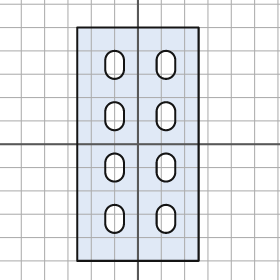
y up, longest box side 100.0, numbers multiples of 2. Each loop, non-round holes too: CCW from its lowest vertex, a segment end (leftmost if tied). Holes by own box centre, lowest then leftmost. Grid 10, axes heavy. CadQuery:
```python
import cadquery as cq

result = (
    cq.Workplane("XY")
    .moveTo(-26.0, -50.0)
    .lineTo(26.0, -50.0)
    .lineTo(26.0, 50.0)
    .lineTo(-26.0, 50.0)
    .close()
    .moveTo(-14.0, -34.0)
    .threePointArc((-10.0, -38.0), (-6.0, -34.0))
    .lineTo(-6.0, -30.0)
    .threePointArc((-10.0, -26.0), (-14.0, -30.0))
    .close()
    .moveTo(8.0, -34.0)
    .threePointArc((12.0, -38.0), (16.0, -34.0))
    .lineTo(16.0, -30.0)
    .threePointArc((12.0, -26.0), (8.0, -30.0))
    .close()
    .moveTo(-14.0, -12.0)
    .threePointArc((-10.0, -16.0), (-6.0, -12.0))
    .lineTo(-6.0, -8.0)
    .threePointArc((-10.0, -4.0), (-14.0, -8.0))
    .close()
    .moveTo(8.0, -12.0)
    .threePointArc((12.0, -16.0), (16.0, -12.0))
    .lineTo(16.0, -8.0)
    .threePointArc((12.0, -4.0), (8.0, -8.0))
    .close()
    .moveTo(-14.0, 10.0)
    .threePointArc((-10.0, 6.0), (-6.0, 10.0))
    .lineTo(-6.0, 14.0)
    .threePointArc((-10.0, 18.0), (-14.0, 14.0))
    .close()
    .moveTo(8.0, 10.0)
    .threePointArc((12.0, 6.0), (16.0, 10.0))
    .lineTo(16.0, 14.0)
    .threePointArc((12.0, 18.0), (8.0, 14.0))
    .close()
    .moveTo(-14.0, 32.0)
    .threePointArc((-10.0, 28.0), (-6.0, 32.0))
    .lineTo(-6.0, 36.0)
    .threePointArc((-10.0, 40.0), (-14.0, 36.0))
    .close()
    .moveTo(8.0, 32.0)
    .threePointArc((12.0, 28.0), (16.0, 32.0))
    .lineTo(16.0, 36.0)
    .threePointArc((12.0, 40.0), (8.0, 36.0))
    .close()
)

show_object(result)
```